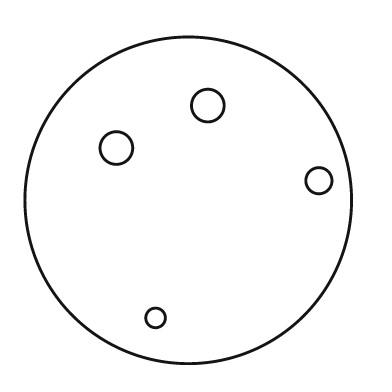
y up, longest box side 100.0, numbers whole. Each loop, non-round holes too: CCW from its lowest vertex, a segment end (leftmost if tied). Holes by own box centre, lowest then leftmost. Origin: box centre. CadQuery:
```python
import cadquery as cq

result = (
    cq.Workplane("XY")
    .moveTo(0.0, 0.0)
    .circle(50.0)
    .moveTo(-10.0, -36.0)
    .circle(3.0)
    .moveTo(40.0, 6.0)
    .circle(4.0)
    .moveTo(-22.0, 16.0)
    .circle(5.0)
    .moveTo(6.0, 29.0)
    .circle(5.0)
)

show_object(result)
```